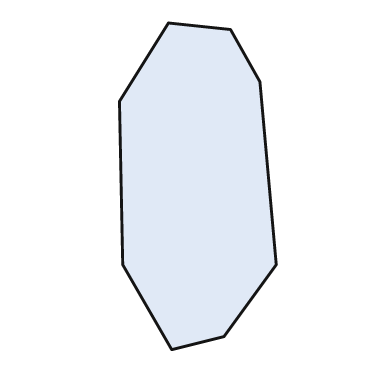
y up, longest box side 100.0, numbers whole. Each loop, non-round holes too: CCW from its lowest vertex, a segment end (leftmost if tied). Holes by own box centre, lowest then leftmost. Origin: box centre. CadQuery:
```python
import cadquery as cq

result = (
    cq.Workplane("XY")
    .moveTo(-8.0, -50.0)
    .lineTo(8.0, -46.0)
    .lineTo(24.0, -24.0)
    .lineTo(19.0, 32.0)
    .lineTo(10.0, 48.0)
    .lineTo(-9.0, 50.0)
    .lineTo(-24.0, 26.0)
    .lineTo(-23.0, -24.0)
    .close()
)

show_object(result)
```